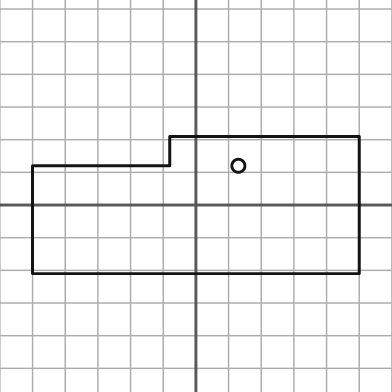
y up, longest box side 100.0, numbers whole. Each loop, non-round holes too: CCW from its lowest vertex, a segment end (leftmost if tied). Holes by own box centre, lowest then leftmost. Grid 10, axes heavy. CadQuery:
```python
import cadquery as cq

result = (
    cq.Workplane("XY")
    .moveTo(-50.0, -21.0)
    .lineTo(50.0, -21.0)
    .lineTo(50.0, 21.0)
    .lineTo(-8.0, 21.0)
    .lineTo(-8.0, 12.0)
    .lineTo(-50.0, 12.0)
    .close()
    .moveTo(13.0, 12.0)
    .circle(2.0)
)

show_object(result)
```